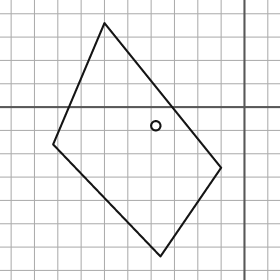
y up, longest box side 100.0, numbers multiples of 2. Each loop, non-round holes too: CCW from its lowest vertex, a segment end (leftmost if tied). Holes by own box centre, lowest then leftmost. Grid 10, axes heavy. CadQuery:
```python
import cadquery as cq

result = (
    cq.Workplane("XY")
    .moveTo(-36.0, -64.0)
    .lineTo(-10.0, -26.0)
    .lineTo(-60.0, 36.0)
    .lineTo(-82.0, -16.0)
    .close()
    .moveTo(-38.0, -8.0)
    .circle(2.0)
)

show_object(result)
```